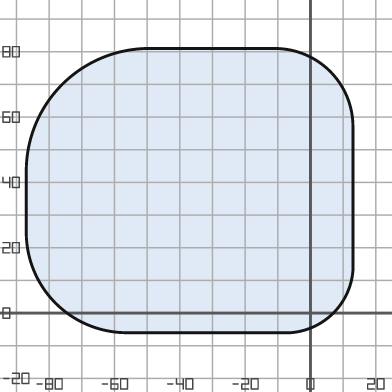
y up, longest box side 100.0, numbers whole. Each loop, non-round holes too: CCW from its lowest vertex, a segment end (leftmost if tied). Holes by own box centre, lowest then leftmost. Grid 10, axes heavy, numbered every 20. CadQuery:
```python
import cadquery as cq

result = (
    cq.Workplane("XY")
    .moveTo(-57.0, -6.0)
    .lineTo(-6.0, -6.0)
    .threePointArc((7.0, 0.0), (13.0, 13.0))
    .lineTo(13.0, 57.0)
    .threePointArc((6.0, 74.0), (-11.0, 81.0))
    .lineTo(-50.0, 81.0)
    .threePointArc((-76.0, 70.0), (-87.0, 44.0))
    .lineTo(-87.0, 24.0)
    .threePointArc((-78.0, 3.0), (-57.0, -6.0))
    .close()
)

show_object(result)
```